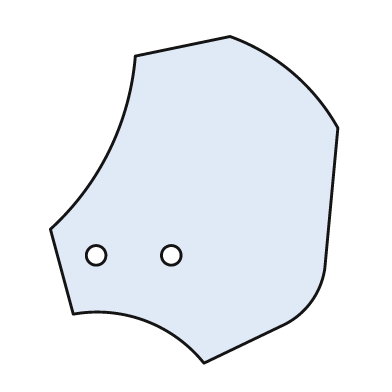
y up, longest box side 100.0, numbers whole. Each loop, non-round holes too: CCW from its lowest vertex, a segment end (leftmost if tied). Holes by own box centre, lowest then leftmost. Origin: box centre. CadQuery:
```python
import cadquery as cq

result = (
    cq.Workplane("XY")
    .moveTo(3.0, -50.0)
    .lineTo(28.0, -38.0)
    .threePointArc((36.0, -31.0), (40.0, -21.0))
    .lineTo(44.0, 22.0)
    .threePointArc((30.0, 39.0), (11.0, 50.0))
    .lineTo(-18.0, 44.0)
    .threePointArc((-26.0, 15.0), (-44.0, -9.0))
    .lineTo(-37.0, -35.0)
    .threePointArc((-15.0, -37.0), (3.0, -50.0))
    .close()
    .moveTo(-30.0, -17.0)
    .circle(3.0)
    .moveTo(-7.0, -17.0)
    .circle(3.0)
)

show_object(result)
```